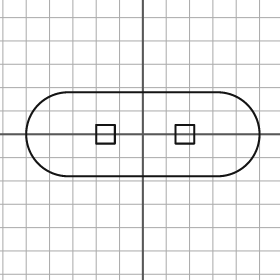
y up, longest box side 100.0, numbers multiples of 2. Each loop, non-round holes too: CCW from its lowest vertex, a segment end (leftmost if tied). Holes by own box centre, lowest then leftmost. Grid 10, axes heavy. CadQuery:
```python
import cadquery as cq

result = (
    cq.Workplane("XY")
    .moveTo(-32.0, -18.0)
    .lineTo(32.0, -18.0)
    .threePointArc((50.0, 0.0), (32.0, 18.0))
    .lineTo(-32.0, 18.0)
    .threePointArc((-50.0, 0.0), (-32.0, -18.0))
    .close()
    .moveTo(-20.0, -4.0)
    .lineTo(-12.0, -4.0)
    .lineTo(-12.0, 4.0)
    .lineTo(-20.0, 4.0)
    .close()
    .moveTo(14.0, -4.0)
    .lineTo(22.0, -4.0)
    .lineTo(22.0, 4.0)
    .lineTo(14.0, 4.0)
    .close()
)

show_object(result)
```